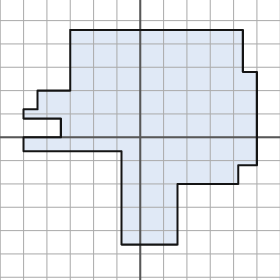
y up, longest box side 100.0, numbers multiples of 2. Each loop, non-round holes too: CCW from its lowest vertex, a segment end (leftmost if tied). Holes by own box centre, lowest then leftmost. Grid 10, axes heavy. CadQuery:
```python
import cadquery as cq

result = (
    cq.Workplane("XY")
    .moveTo(-8.0, -46.0)
    .lineTo(16.0, -46.0)
    .lineTo(16.0, -20.0)
    .lineTo(42.0, -20.0)
    .lineTo(42.0, -12.0)
    .lineTo(50.0, -12.0)
    .lineTo(50.0, 28.0)
    .lineTo(44.0, 28.0)
    .lineTo(44.0, 46.0)
    .lineTo(-30.0, 46.0)
    .lineTo(-30.0, 20.0)
    .lineTo(-44.0, 20.0)
    .lineTo(-44.0, 12.0)
    .lineTo(-50.0, 12.0)
    .lineTo(-50.0, 8.0)
    .lineTo(-34.0, 8.0)
    .lineTo(-34.0, 0.0)
    .lineTo(-50.0, 0.0)
    .lineTo(-50.0, -6.0)
    .lineTo(-8.0, -6.0)
    .close()
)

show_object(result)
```